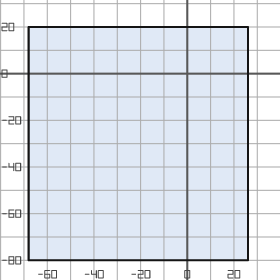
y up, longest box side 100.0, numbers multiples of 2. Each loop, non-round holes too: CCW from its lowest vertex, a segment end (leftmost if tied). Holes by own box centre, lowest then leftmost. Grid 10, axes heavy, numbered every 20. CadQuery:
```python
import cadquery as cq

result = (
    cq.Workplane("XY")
    .moveTo(-68.0, -80.0)
    .lineTo(26.0, -80.0)
    .lineTo(26.0, 20.0)
    .lineTo(-68.0, 20.0)
    .close()
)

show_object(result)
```